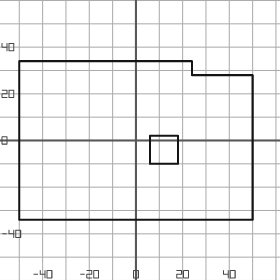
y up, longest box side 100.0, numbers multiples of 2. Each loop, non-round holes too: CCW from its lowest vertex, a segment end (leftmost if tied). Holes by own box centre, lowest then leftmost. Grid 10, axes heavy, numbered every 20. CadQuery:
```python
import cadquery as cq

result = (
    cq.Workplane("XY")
    .moveTo(-50.0, -34.0)
    .lineTo(50.0, -34.0)
    .lineTo(50.0, 28.0)
    .lineTo(24.0, 28.0)
    .lineTo(24.0, 34.0)
    .lineTo(-50.0, 34.0)
    .close()
    .moveTo(6.0, -10.0)
    .lineTo(18.0, -10.0)
    .lineTo(18.0, 2.0)
    .lineTo(6.0, 2.0)
    .close()
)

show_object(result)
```